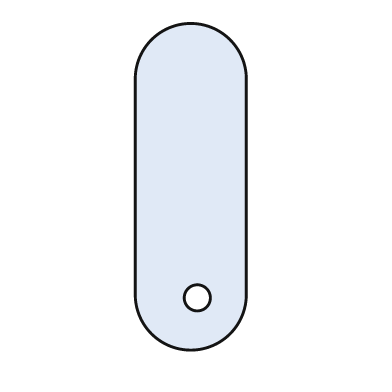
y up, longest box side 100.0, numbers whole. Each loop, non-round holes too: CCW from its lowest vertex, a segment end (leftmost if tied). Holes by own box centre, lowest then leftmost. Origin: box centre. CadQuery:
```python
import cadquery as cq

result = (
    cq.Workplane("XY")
    .moveTo(-17.0, -33.0)
    .threePointArc((0.0, -50.0), (17.0, -33.0))
    .lineTo(17.0, 33.0)
    .threePointArc((0.0, 50.0), (-17.0, 33.0))
    .close()
    .moveTo(2.0, -34.0)
    .circle(4.0)
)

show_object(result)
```